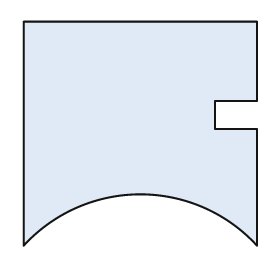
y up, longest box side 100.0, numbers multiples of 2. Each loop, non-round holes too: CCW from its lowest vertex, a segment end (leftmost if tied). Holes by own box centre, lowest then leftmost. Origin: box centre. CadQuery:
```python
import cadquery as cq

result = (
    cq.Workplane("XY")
    .moveTo(-50.0, -48.0)
    .threePointArc((0.0, -26.0), (50.0, -48.0))
    .lineTo(50.0, 2.0)
    .lineTo(32.0, 2.0)
    .lineTo(32.0, 14.0)
    .lineTo(50.0, 14.0)
    .lineTo(50.0, 48.0)
    .lineTo(-50.0, 48.0)
    .close()
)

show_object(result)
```